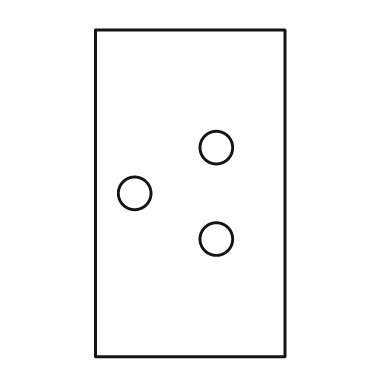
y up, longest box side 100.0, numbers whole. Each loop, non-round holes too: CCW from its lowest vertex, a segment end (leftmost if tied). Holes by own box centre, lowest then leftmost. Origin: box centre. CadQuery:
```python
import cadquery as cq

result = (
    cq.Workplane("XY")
    .moveTo(-29.0, -50.0)
    .lineTo(29.0, -50.0)
    .lineTo(29.0, 50.0)
    .lineTo(-29.0, 50.0)
    .close()
    .moveTo(8.0, -14.0)
    .circle(5.0)
    .moveTo(-17.0, 0.0)
    .circle(5.0)
    .moveTo(8.0, 14.0)
    .circle(5.0)
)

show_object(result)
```